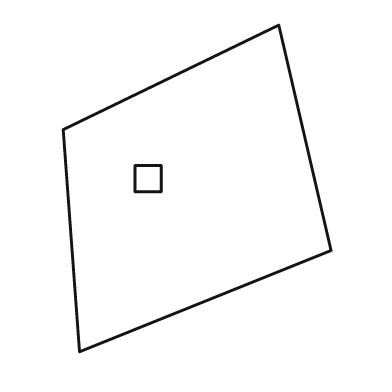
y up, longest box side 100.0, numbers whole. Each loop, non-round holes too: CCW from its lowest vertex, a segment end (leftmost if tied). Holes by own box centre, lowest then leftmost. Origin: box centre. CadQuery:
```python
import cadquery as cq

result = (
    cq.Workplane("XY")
    .moveTo(-36.0, -50.0)
    .lineTo(41.0, -19.0)
    .lineTo(25.0, 50.0)
    .lineTo(-41.0, 18.0)
    .close()
    .moveTo(-19.0, -1.0)
    .lineTo(-11.0, -1.0)
    .lineTo(-11.0, 7.0)
    .lineTo(-19.0, 7.0)
    .close()
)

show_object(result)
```